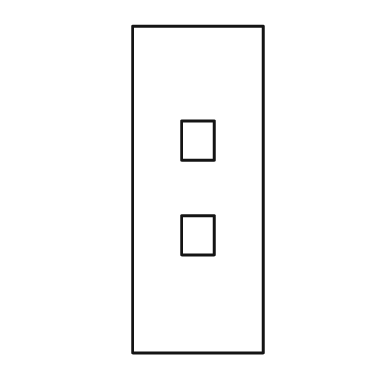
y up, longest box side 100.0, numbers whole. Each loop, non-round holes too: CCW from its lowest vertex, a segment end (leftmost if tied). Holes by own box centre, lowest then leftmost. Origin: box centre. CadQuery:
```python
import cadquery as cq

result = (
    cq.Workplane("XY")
    .moveTo(-20.0, -50.0)
    .lineTo(20.0, -50.0)
    .lineTo(20.0, 50.0)
    .lineTo(-20.0, 50.0)
    .close()
    .moveTo(-5.0, -20.0)
    .lineTo(5.0, -20.0)
    .lineTo(5.0, -8.0)
    .lineTo(-5.0, -8.0)
    .close()
    .moveTo(-5.0, 9.0)
    .lineTo(5.0, 9.0)
    .lineTo(5.0, 21.0)
    .lineTo(-5.0, 21.0)
    .close()
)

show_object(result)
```